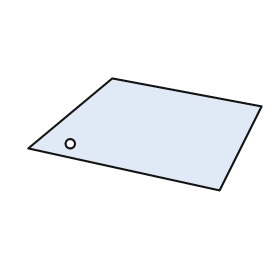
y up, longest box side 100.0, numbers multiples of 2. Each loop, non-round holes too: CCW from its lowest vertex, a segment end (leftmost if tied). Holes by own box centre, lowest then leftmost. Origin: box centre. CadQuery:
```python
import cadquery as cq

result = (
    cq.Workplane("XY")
    .moveTo(32.0, -24.0)
    .lineTo(50.0, 12.0)
    .lineTo(-14.0, 24.0)
    .lineTo(-50.0, -6.0)
    .close()
    .moveTo(-32.0, -4.0)
    .circle(2.0)
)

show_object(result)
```